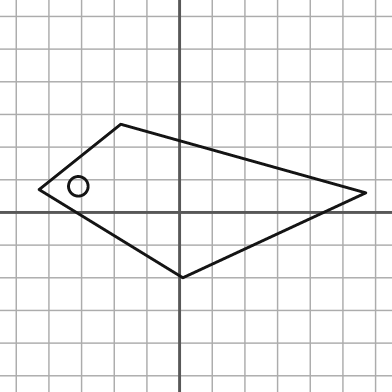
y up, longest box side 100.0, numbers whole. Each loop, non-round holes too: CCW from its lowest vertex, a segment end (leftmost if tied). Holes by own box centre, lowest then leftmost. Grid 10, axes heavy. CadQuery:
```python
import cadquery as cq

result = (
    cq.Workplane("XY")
    .moveTo(1.0, -20.0)
    .lineTo(57.0, 6.0)
    .lineTo(-18.0, 27.0)
    .lineTo(-43.0, 7.0)
    .close()
    .moveTo(-31.0, 8.0)
    .circle(3.0)
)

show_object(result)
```